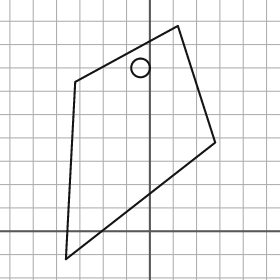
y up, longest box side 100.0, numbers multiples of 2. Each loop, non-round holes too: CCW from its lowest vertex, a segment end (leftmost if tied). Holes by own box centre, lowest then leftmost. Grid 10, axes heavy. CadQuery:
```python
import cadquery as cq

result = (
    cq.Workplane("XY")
    .moveTo(-36.0, -12.0)
    .lineTo(28.0, 38.0)
    .lineTo(12.0, 88.0)
    .lineTo(-32.0, 64.0)
    .close()
    .moveTo(-4.0, 70.0)
    .circle(4.0)
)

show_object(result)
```